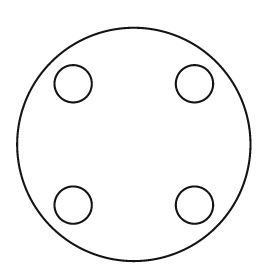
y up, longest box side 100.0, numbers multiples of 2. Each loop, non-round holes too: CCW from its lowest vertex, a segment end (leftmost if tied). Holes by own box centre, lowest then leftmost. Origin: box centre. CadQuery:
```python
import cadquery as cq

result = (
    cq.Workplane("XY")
    .moveTo(0.0, 0.0)
    .circle(50.0)
    .moveTo(-26.0, -26.0)
    .circle(8.0)
    .moveTo(26.0, -26.0)
    .circle(8.0)
    .moveTo(-26.0, 26.0)
    .circle(8.0)
    .moveTo(26.0, 26.0)
    .circle(8.0)
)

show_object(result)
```